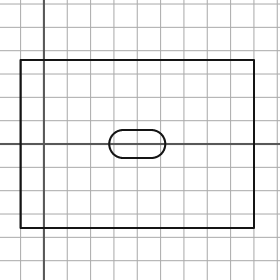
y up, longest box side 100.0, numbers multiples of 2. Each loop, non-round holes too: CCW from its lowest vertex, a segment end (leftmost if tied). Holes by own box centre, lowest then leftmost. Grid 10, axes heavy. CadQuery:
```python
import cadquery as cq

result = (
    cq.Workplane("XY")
    .moveTo(-10.0, -36.0)
    .lineTo(90.0, -36.0)
    .lineTo(90.0, 36.0)
    .lineTo(-10.0, 36.0)
    .close()
    .moveTo(34.0, -6.0)
    .lineTo(46.0, -6.0)
    .threePointArc((52.0, 0.0), (46.0, 6.0))
    .lineTo(34.0, 6.0)
    .threePointArc((28.0, 0.0), (34.0, -6.0))
    .close()
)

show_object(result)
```